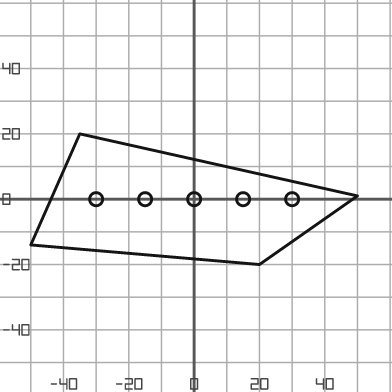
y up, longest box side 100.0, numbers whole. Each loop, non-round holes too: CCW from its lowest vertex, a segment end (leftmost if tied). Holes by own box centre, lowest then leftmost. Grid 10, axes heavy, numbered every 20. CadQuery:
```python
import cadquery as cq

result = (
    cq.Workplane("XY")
    .moveTo(20.0, -20.0)
    .lineTo(50.0, 1.0)
    .lineTo(-35.0, 20.0)
    .lineTo(-50.0, -14.0)
    .close()
    .moveTo(-30.0, 0.0)
    .circle(2.0)
    .moveTo(-15.0, 0.0)
    .circle(2.0)
    .moveTo(0.0, 0.0)
    .circle(2.0)
    .moveTo(15.0, 0.0)
    .circle(2.0)
    .moveTo(30.0, 0.0)
    .circle(2.0)
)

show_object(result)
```